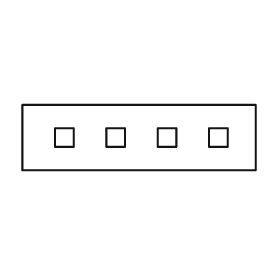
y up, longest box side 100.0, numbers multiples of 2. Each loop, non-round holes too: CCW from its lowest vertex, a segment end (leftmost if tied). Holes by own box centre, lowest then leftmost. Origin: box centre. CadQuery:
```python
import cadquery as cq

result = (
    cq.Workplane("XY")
    .moveTo(-50.0, -14.0)
    .lineTo(50.0, -14.0)
    .lineTo(50.0, 14.0)
    .lineTo(-50.0, 14.0)
    .close()
    .moveTo(-36.0, -4.0)
    .lineTo(-28.0, -4.0)
    .lineTo(-28.0, 4.0)
    .lineTo(-36.0, 4.0)
    .close()
    .moveTo(-14.0, -4.0)
    .lineTo(-6.0, -4.0)
    .lineTo(-6.0, 4.0)
    .lineTo(-14.0, 4.0)
    .close()
    .moveTo(8.0, -4.0)
    .lineTo(16.0, -4.0)
    .lineTo(16.0, 4.0)
    .lineTo(8.0, 4.0)
    .close()
    .moveTo(30.0, -4.0)
    .lineTo(38.0, -4.0)
    .lineTo(38.0, 4.0)
    .lineTo(30.0, 4.0)
    .close()
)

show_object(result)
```